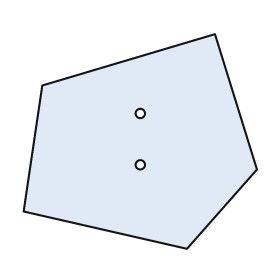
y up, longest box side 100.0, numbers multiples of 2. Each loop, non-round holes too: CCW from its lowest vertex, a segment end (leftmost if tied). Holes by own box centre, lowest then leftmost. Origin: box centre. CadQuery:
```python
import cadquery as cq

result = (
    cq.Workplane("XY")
    .moveTo(20.0, -46.0)
    .lineTo(50.0, -12.0)
    .lineTo(32.0, 46.0)
    .lineTo(-42.0, 24.0)
    .lineTo(-50.0, -30.0)
    .close()
    .moveTo(0.0, -10.0)
    .circle(2.0)
    .moveTo(0.0, 12.0)
    .circle(2.0)
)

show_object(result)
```